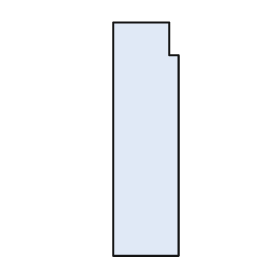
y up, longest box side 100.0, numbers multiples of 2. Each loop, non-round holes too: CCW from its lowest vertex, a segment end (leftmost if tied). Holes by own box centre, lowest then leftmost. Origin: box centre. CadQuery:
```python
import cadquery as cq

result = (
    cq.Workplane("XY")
    .moveTo(-14.0, -50.0)
    .lineTo(14.0, -50.0)
    .lineTo(14.0, 36.0)
    .lineTo(10.0, 36.0)
    .lineTo(10.0, 50.0)
    .lineTo(-14.0, 50.0)
    .close()
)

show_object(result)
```